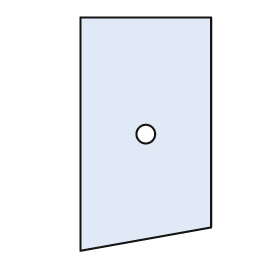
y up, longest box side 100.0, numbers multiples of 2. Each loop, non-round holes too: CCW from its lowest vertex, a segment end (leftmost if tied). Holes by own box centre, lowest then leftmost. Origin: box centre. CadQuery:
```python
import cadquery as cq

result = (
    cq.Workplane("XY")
    .moveTo(-28.0, -50.0)
    .lineTo(28.0, -40.0)
    .lineTo(28.0, 50.0)
    .lineTo(-28.0, 50.0)
    .close()
    .moveTo(0.0, 0.0)
    .circle(4.0)
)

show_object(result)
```